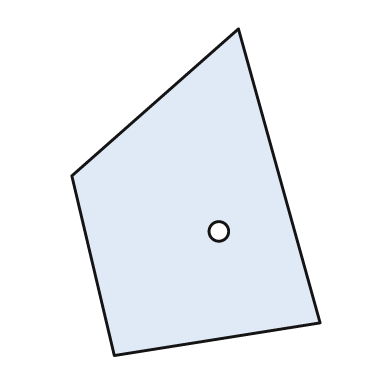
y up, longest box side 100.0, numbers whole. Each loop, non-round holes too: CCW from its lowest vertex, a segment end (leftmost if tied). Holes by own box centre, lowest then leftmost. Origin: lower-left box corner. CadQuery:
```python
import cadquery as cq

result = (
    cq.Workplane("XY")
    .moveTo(13.0, 0.0)
    .lineTo(76.0, 10.0)
    .lineTo(51.0, 100.0)
    .lineTo(0.0, 55.0)
    .close()
    .moveTo(45.0, 38.0)
    .circle(3.0)
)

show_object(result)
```